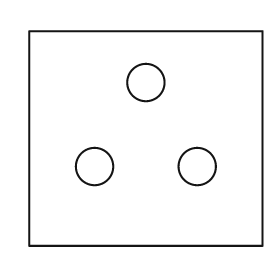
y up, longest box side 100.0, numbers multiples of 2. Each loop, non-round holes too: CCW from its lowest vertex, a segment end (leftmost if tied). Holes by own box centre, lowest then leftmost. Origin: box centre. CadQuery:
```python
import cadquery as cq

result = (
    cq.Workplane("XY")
    .moveTo(-50.0, -46.0)
    .lineTo(50.0, -46.0)
    .lineTo(50.0, 46.0)
    .lineTo(-50.0, 46.0)
    .close()
    .moveTo(-22.0, -12.0)
    .circle(8.0)
    .moveTo(22.0, -12.0)
    .circle(8.0)
    .moveTo(0.0, 24.0)
    .circle(8.0)
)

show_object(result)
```